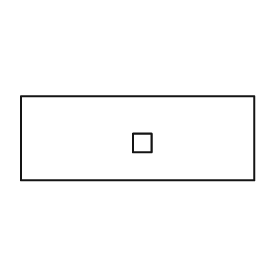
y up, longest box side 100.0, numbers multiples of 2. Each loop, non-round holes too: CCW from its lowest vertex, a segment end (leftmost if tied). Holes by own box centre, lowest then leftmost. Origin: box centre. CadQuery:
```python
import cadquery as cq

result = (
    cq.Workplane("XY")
    .moveTo(-50.0, -18.0)
    .lineTo(50.0, -18.0)
    .lineTo(50.0, 18.0)
    .lineTo(-50.0, 18.0)
    .close()
    .moveTo(-2.0, -6.0)
    .lineTo(6.0, -6.0)
    .lineTo(6.0, 2.0)
    .lineTo(-2.0, 2.0)
    .close()
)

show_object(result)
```